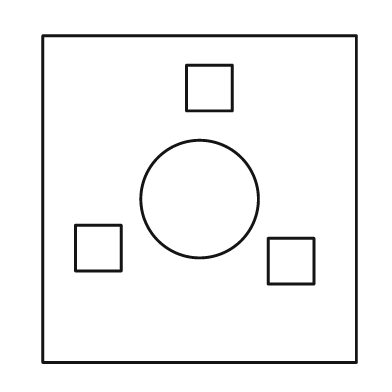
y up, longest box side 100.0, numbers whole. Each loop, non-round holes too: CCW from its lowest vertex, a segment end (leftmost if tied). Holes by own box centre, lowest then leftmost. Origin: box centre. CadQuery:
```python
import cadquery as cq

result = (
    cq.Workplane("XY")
    .moveTo(-48.0, -50.0)
    .lineTo(48.0, -50.0)
    .lineTo(48.0, 50.0)
    .lineTo(-48.0, 50.0)
    .close()
    .moveTo(21.0, -26.0)
    .lineTo(35.0, -26.0)
    .lineTo(35.0, -12.0)
    .lineTo(21.0, -12.0)
    .close()
    .moveTo(-38.0, -22.0)
    .lineTo(-24.0, -22.0)
    .lineTo(-24.0, -8.0)
    .lineTo(-38.0, -8.0)
    .close()
    .moveTo(0.0, 0.0)
    .circle(18.0)
    .moveTo(-4.0, 27.0)
    .lineTo(10.0, 27.0)
    .lineTo(10.0, 41.0)
    .lineTo(-4.0, 41.0)
    .close()
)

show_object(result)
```